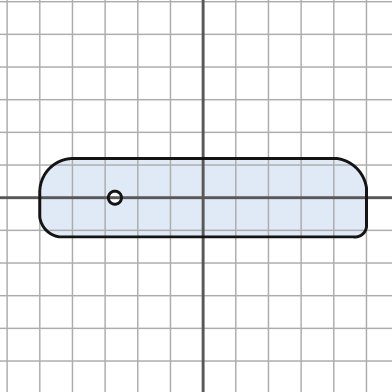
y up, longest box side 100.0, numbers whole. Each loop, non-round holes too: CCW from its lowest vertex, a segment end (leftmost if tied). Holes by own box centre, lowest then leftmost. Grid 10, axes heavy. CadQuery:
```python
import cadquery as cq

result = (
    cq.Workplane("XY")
    .moveTo(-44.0, -12.0)
    .lineTo(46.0, -12.0)
    .threePointArc((49.0, -11.0), (50.0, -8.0))
    .lineTo(50.0, 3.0)
    .threePointArc((47.0, 9.0), (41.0, 12.0))
    .lineTo(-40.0, 12.0)
    .threePointArc((-47.0, 9.0), (-50.0, 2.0))
    .lineTo(-50.0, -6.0)
    .threePointArc((-48.0, -10.0), (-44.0, -12.0))
    .close()
    .moveTo(-27.0, 0.0)
    .circle(2.0)
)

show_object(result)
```